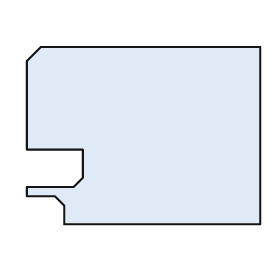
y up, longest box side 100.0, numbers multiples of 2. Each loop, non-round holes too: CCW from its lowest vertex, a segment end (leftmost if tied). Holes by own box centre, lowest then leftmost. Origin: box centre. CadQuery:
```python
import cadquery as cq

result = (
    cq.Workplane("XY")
    .moveTo(-34.0, -38.0)
    .lineTo(50.0, -38.0)
    .lineTo(50.0, 38.0)
    .lineTo(-44.0, 38.0)
    .lineTo(-50.0, 32.0)
    .lineTo(-50.0, -6.0)
    .lineTo(-26.0, -6.0)
    .lineTo(-26.0, -18.0)
    .lineTo(-30.0, -22.0)
    .lineTo(-50.0, -22.0)
    .lineTo(-50.0, -26.0)
    .lineTo(-38.0, -26.0)
    .lineTo(-34.0, -30.0)
    .close()
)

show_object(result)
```